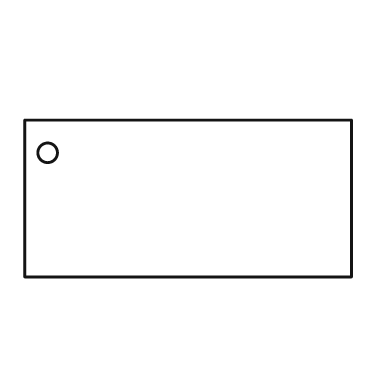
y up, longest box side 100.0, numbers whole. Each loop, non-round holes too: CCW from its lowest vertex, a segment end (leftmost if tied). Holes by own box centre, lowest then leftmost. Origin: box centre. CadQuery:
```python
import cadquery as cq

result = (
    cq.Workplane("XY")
    .moveTo(-50.0, -24.0)
    .lineTo(50.0, -24.0)
    .lineTo(50.0, 24.0)
    .lineTo(-50.0, 24.0)
    .close()
    .moveTo(-43.0, 14.0)
    .circle(3.0)
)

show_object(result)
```